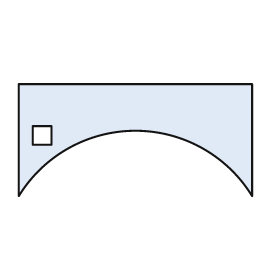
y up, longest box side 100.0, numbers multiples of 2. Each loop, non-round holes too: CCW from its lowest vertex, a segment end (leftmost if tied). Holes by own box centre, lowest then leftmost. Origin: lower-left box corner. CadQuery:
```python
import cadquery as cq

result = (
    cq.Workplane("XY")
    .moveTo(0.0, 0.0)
    .threePointArc((50.0, 28.0), (100.0, 0.0))
    .lineTo(100.0, 48.0)
    .lineTo(0.0, 48.0)
    .close()
    .moveTo(6.0, 22.0)
    .lineTo(14.0, 22.0)
    .lineTo(14.0, 30.0)
    .lineTo(6.0, 30.0)
    .close()
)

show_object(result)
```